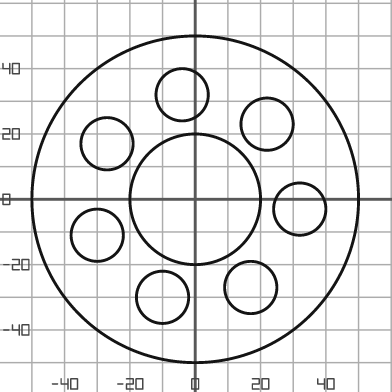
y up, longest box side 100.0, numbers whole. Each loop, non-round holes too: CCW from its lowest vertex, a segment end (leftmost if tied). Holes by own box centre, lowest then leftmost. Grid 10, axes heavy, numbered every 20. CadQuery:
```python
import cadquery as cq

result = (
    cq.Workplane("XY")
    .moveTo(0.0, 0.0)
    .circle(50.0)
    .moveTo(-10.0, -30.0)
    .circle(8.0)
    .moveTo(17.0, -27.0)
    .circle(8.0)
    .moveTo(-30.0, -11.0)
    .circle(8.0)
    .moveTo(32.0, -3.0)
    .circle(8.0)
    .moveTo(0.0, 0.0)
    .circle(20.0)
    .moveTo(-27.0, 17.0)
    .circle(8.0)
    .moveTo(22.0, 23.0)
    .circle(8.0)
    .moveTo(-4.0, 32.0)
    .circle(8.0)
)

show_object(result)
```